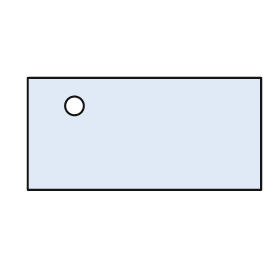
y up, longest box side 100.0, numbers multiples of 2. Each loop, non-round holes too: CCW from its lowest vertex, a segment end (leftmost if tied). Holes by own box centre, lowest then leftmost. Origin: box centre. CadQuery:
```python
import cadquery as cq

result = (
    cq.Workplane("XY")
    .moveTo(-50.0, -24.0)
    .lineTo(50.0, -24.0)
    .lineTo(50.0, 24.0)
    .lineTo(-50.0, 24.0)
    .close()
    .moveTo(-30.0, 12.0)
    .circle(4.0)
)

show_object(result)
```